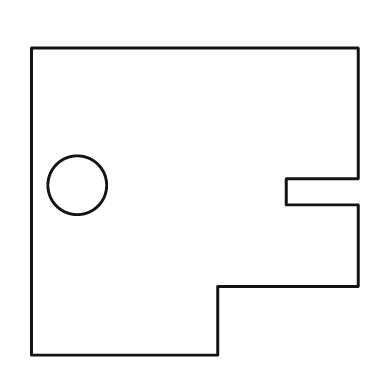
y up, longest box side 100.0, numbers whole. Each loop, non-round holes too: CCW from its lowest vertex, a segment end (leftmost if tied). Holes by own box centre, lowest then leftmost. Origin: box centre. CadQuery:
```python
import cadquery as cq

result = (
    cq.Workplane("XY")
    .moveTo(-50.0, -47.0)
    .lineTo(7.0, -47.0)
    .lineTo(7.0, -26.0)
    .lineTo(50.0, -26.0)
    .lineTo(50.0, -1.0)
    .lineTo(28.0, -1.0)
    .lineTo(28.0, 7.0)
    .lineTo(50.0, 7.0)
    .lineTo(50.0, 47.0)
    .lineTo(-50.0, 47.0)
    .close()
    .moveTo(-36.0, 5.0)
    .circle(9.0)
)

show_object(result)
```